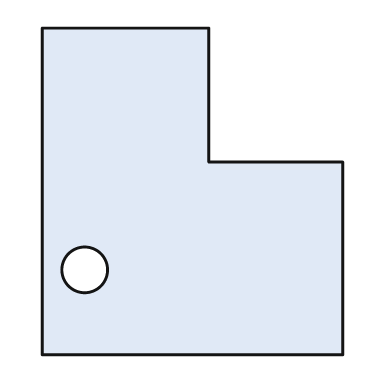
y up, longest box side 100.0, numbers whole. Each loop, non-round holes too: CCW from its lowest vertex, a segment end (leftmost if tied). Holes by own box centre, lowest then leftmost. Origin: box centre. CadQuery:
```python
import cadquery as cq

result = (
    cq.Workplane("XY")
    .moveTo(-46.0, -50.0)
    .lineTo(46.0, -50.0)
    .lineTo(46.0, 9.0)
    .lineTo(5.0, 9.0)
    .lineTo(5.0, 50.0)
    .lineTo(-46.0, 50.0)
    .close()
    .moveTo(-33.0, -24.0)
    .circle(7.0)
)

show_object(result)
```